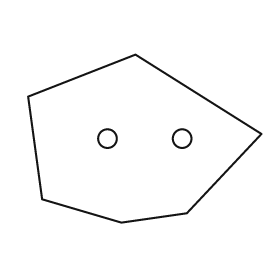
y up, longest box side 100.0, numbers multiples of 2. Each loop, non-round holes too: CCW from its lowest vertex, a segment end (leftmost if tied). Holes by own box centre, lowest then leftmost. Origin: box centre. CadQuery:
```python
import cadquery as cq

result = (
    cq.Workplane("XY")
    .moveTo(-10.0, -36.0)
    .lineTo(18.0, -32.0)
    .lineTo(50.0, 2.0)
    .lineTo(-4.0, 36.0)
    .lineTo(-50.0, 18.0)
    .lineTo(-44.0, -26.0)
    .close()
    .moveTo(-16.0, 0.0)
    .circle(4.0)
    .moveTo(16.0, 0.0)
    .circle(4.0)
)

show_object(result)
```